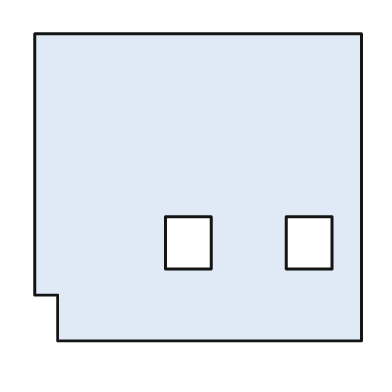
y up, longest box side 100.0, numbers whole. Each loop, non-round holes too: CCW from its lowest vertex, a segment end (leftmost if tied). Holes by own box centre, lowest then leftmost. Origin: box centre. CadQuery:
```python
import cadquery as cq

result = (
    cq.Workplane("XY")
    .moveTo(-43.0, -47.0)
    .lineTo(50.0, -47.0)
    .lineTo(50.0, 47.0)
    .lineTo(-50.0, 47.0)
    .lineTo(-50.0, -33.0)
    .lineTo(-43.0, -33.0)
    .close()
    .moveTo(-10.0, -25.0)
    .lineTo(4.0, -25.0)
    .lineTo(4.0, -9.0)
    .lineTo(-10.0, -9.0)
    .close()
    .moveTo(27.0, -25.0)
    .lineTo(41.0, -25.0)
    .lineTo(41.0, -9.0)
    .lineTo(27.0, -9.0)
    .close()
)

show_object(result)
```